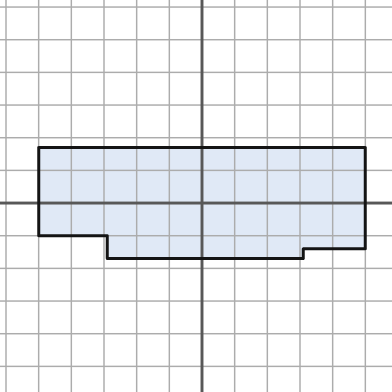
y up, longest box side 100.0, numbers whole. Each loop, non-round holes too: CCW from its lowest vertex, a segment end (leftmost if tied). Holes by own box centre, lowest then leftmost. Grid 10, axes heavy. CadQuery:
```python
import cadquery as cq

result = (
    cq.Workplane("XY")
    .moveTo(-29.0, -17.0)
    .lineTo(31.0, -17.0)
    .lineTo(31.0, -14.0)
    .lineTo(50.0, -14.0)
    .lineTo(50.0, 17.0)
    .lineTo(-50.0, 17.0)
    .lineTo(-50.0, -10.0)
    .lineTo(-29.0, -10.0)
    .close()
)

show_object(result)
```